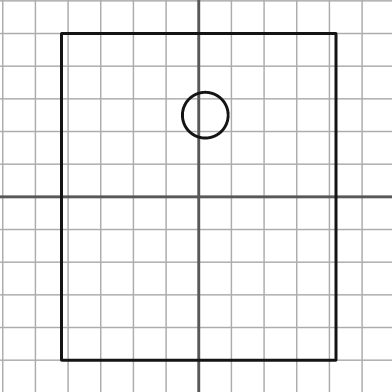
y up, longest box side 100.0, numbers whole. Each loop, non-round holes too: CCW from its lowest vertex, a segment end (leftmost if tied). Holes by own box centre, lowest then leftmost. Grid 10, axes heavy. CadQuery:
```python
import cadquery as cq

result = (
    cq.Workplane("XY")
    .moveTo(-42.0, -50.0)
    .lineTo(42.0, -50.0)
    .lineTo(42.0, 50.0)
    .lineTo(-42.0, 50.0)
    .close()
    .moveTo(2.0, 25.0)
    .circle(7.0)
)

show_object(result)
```